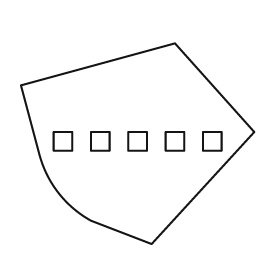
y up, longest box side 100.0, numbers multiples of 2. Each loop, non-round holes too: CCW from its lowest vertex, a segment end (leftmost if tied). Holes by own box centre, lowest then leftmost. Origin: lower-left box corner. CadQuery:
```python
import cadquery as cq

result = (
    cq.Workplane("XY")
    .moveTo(56.0, 0.0)
    .lineTo(100.0, 48.0)
    .lineTo(66.0, 86.0)
    .lineTo(0.0, 68.0)
    .lineTo(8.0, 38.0)
    .threePointArc((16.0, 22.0), (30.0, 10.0))
    .close()
    .moveTo(14.0, 40.0)
    .lineTo(22.0, 40.0)
    .lineTo(22.0, 48.0)
    .lineTo(14.0, 48.0)
    .close()
    .moveTo(30.0, 40.0)
    .lineTo(38.0, 40.0)
    .lineTo(38.0, 48.0)
    .lineTo(30.0, 48.0)
    .close()
    .moveTo(46.0, 40.0)
    .lineTo(54.0, 40.0)
    .lineTo(54.0, 48.0)
    .lineTo(46.0, 48.0)
    .close()
    .moveTo(62.0, 40.0)
    .lineTo(70.0, 40.0)
    .lineTo(70.0, 48.0)
    .lineTo(62.0, 48.0)
    .close()
    .moveTo(78.0, 40.0)
    .lineTo(86.0, 40.0)
    .lineTo(86.0, 48.0)
    .lineTo(78.0, 48.0)
    .close()
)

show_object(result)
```